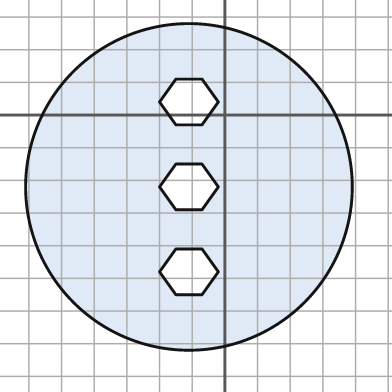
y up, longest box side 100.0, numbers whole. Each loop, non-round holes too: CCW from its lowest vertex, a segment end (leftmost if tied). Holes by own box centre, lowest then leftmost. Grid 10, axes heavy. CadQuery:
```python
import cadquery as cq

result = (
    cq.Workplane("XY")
    .moveTo(-11.0, -22.0)
    .circle(50.0)
    .moveTo(-15.0, -55.0)
    .lineTo(-7.0, -55.0)
    .lineTo(-2.0, -48.0)
    .lineTo(-7.0, -41.0)
    .lineTo(-15.0, -41.0)
    .lineTo(-20.0, -48.0)
    .close()
    .moveTo(-15.0, -29.0)
    .lineTo(-7.0, -29.0)
    .lineTo(-2.0, -22.0)
    .lineTo(-7.0, -15.0)
    .lineTo(-15.0, -15.0)
    .lineTo(-20.0, -22.0)
    .close()
    .moveTo(-15.0, -3.0)
    .lineTo(-7.0, -3.0)
    .lineTo(-2.0, 4.0)
    .lineTo(-7.0, 11.0)
    .lineTo(-15.0, 11.0)
    .lineTo(-20.0, 4.0)
    .close()
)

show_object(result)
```